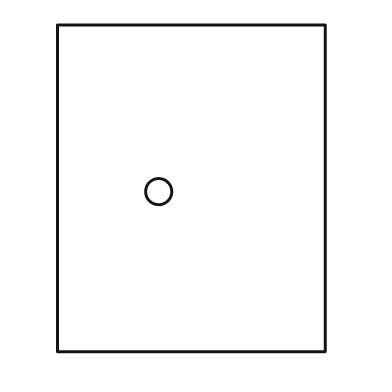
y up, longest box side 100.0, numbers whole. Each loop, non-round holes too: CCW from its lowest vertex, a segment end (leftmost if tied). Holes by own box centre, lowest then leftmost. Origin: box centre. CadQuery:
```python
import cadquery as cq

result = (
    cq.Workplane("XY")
    .moveTo(-41.0, -50.0)
    .lineTo(41.0, -50.0)
    .lineTo(41.0, 50.0)
    .lineTo(-41.0, 50.0)
    .close()
    .moveTo(-10.0, -1.0)
    .circle(4.0)
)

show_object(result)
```